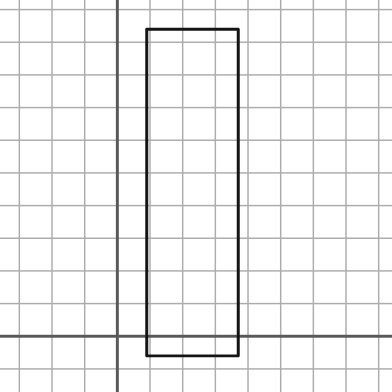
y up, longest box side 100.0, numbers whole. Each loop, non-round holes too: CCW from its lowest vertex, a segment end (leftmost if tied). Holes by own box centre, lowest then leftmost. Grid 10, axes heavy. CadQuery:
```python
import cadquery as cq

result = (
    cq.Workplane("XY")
    .moveTo(9.0, -6.0)
    .lineTo(37.0, -6.0)
    .lineTo(37.0, 94.0)
    .lineTo(9.0, 94.0)
    .close()
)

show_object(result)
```